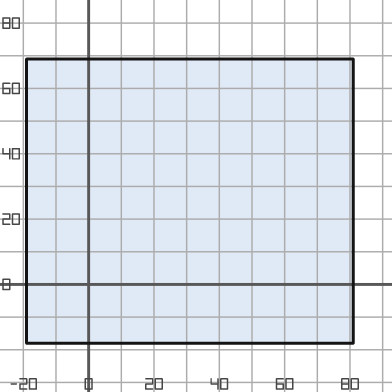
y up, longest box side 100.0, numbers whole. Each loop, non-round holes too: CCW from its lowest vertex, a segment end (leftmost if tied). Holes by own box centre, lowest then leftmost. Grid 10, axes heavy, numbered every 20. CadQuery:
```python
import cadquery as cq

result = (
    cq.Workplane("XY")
    .moveTo(-19.0, -18.0)
    .lineTo(81.0, -18.0)
    .lineTo(81.0, 69.0)
    .lineTo(-19.0, 69.0)
    .close()
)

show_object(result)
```